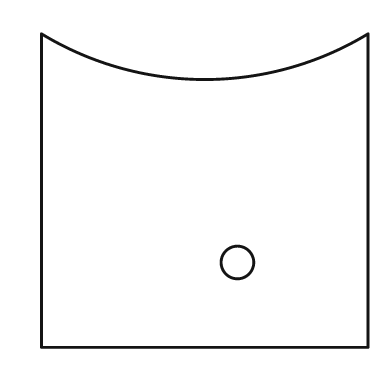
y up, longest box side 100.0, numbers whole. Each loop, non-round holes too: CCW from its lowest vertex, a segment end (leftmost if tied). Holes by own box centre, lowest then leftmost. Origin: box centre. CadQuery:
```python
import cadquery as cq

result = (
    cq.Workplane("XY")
    .moveTo(-50.0, -48.0)
    .lineTo(50.0, -48.0)
    .lineTo(50.0, 48.0)
    .threePointArc((0.0, 34.0), (-50.0, 48.0))
    .close()
    .moveTo(10.0, -22.0)
    .circle(5.0)
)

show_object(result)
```